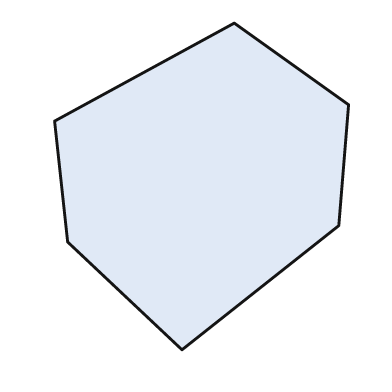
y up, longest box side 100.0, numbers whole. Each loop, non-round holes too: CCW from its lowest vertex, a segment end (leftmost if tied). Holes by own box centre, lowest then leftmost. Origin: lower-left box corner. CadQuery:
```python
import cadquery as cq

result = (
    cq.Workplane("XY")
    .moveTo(39.0, 0.0)
    .lineTo(87.0, 38.0)
    .lineTo(90.0, 75.0)
    .lineTo(55.0, 100.0)
    .lineTo(0.0, 70.0)
    .lineTo(4.0, 33.0)
    .close()
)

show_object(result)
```